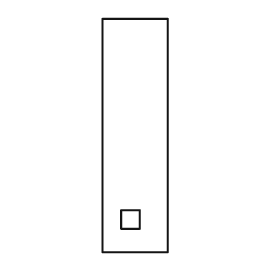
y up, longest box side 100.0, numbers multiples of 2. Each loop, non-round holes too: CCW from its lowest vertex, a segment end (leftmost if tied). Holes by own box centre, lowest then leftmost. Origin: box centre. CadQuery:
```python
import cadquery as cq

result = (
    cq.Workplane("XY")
    .moveTo(-14.0, -50.0)
    .lineTo(14.0, -50.0)
    .lineTo(14.0, 50.0)
    .lineTo(-14.0, 50.0)
    .close()
    .moveTo(-6.0, -40.0)
    .lineTo(2.0, -40.0)
    .lineTo(2.0, -32.0)
    .lineTo(-6.0, -32.0)
    .close()
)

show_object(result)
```